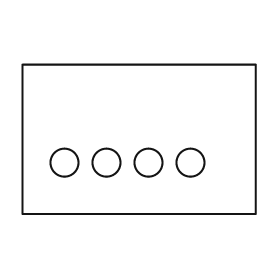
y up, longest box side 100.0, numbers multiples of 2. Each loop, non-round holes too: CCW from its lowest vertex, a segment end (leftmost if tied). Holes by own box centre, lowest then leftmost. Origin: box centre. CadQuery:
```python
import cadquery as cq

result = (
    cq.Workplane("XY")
    .moveTo(-50.0, -32.0)
    .lineTo(50.0, -32.0)
    .lineTo(50.0, 32.0)
    .lineTo(-50.0, 32.0)
    .close()
    .moveTo(-32.0, -10.0)
    .circle(6.0)
    .moveTo(-14.0, -10.0)
    .circle(6.0)
    .moveTo(4.0, -10.0)
    .circle(6.0)
    .moveTo(22.0, -10.0)
    .circle(6.0)
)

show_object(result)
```